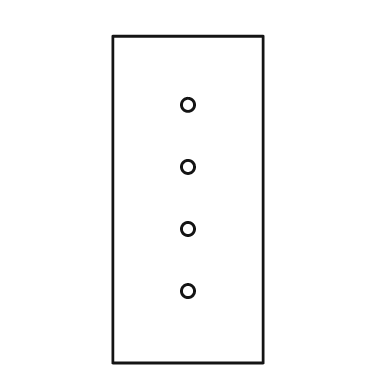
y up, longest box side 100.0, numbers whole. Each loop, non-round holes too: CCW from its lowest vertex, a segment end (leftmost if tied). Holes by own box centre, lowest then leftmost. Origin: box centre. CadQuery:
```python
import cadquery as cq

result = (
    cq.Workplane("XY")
    .moveTo(-23.0, -50.0)
    .lineTo(23.0, -50.0)
    .lineTo(23.0, 50.0)
    .lineTo(-23.0, 50.0)
    .close()
    .moveTo(0.0, -28.0)
    .circle(2.0)
    .moveTo(0.0, -9.0)
    .circle(2.0)
    .moveTo(0.0, 10.0)
    .circle(2.0)
    .moveTo(0.0, 29.0)
    .circle(2.0)
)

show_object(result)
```